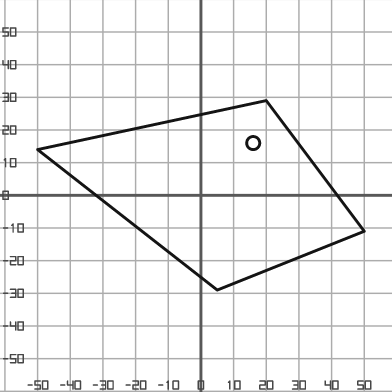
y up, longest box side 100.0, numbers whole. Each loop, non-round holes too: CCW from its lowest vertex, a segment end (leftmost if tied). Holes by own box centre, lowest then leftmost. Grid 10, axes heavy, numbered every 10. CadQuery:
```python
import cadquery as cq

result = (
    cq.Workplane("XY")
    .moveTo(5.0, -29.0)
    .lineTo(50.0, -11.0)
    .lineTo(20.0, 29.0)
    .lineTo(-50.0, 14.0)
    .close()
    .moveTo(16.0, 16.0)
    .circle(2.0)
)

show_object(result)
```